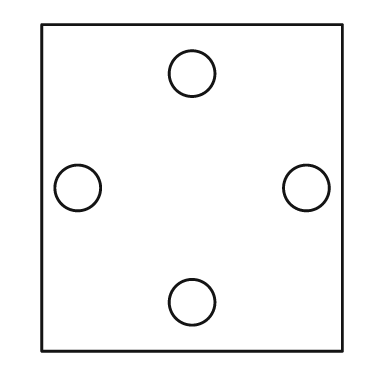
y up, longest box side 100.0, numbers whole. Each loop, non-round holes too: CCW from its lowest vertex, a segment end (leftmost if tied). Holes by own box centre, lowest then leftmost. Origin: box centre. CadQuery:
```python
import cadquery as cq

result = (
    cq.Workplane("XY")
    .moveTo(-46.0, -50.0)
    .lineTo(46.0, -50.0)
    .lineTo(46.0, 50.0)
    .lineTo(-46.0, 50.0)
    .close()
    .moveTo(0.0, -35.0)
    .circle(7.0)
    .moveTo(-35.0, 0.0)
    .circle(7.0)
    .moveTo(35.0, 0.0)
    .circle(7.0)
    .moveTo(0.0, 35.0)
    .circle(7.0)
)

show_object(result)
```